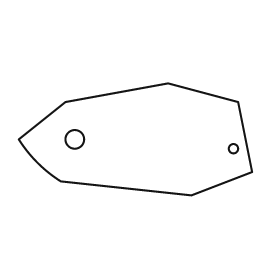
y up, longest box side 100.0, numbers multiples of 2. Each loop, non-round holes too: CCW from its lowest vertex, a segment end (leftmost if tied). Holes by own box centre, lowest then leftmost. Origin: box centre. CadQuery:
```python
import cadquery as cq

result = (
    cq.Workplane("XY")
    .moveTo(24.0, -24.0)
    .lineTo(50.0, -14.0)
    .lineTo(44.0, 16.0)
    .lineTo(14.0, 24.0)
    .lineTo(-30.0, 16.0)
    .lineTo(-50.0, 0.0)
    .threePointArc((-42.0, -10.0), (-32.0, -18.0))
    .close()
    .moveTo(42.0, -4.0)
    .circle(2.0)
    .moveTo(-26.0, 0.0)
    .circle(4.0)
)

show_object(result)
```